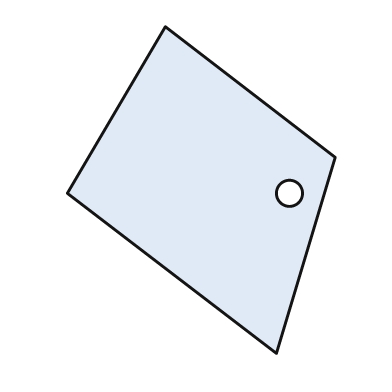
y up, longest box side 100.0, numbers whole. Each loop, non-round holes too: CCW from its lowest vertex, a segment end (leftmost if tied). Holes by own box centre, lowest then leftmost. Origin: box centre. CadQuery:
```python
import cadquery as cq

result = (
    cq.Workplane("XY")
    .moveTo(23.0, -50.0)
    .lineTo(41.0, 10.0)
    .lineTo(-11.0, 50.0)
    .lineTo(-41.0, -1.0)
    .close()
    .moveTo(27.0, -1.0)
    .circle(4.0)
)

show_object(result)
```